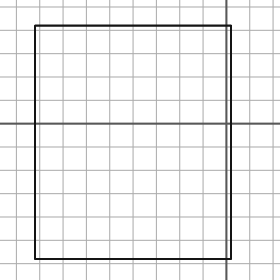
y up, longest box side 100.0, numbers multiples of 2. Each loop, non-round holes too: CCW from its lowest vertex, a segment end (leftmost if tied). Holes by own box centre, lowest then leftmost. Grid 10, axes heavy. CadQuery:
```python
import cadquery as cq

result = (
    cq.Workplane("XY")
    .moveTo(-82.0, -58.0)
    .lineTo(2.0, -58.0)
    .lineTo(2.0, 42.0)
    .lineTo(-82.0, 42.0)
    .close()
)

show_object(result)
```